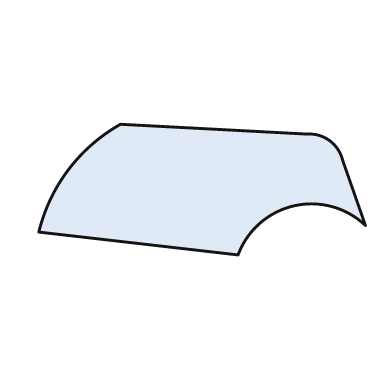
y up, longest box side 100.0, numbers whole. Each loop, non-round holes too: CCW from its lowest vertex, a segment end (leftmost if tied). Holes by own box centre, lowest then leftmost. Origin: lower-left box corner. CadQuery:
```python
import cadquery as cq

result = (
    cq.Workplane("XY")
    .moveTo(61.0, 0.0)
    .threePointArc((78.0, 15.0), (100.0, 9.0))
    .lineTo(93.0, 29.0)
    .threePointArc((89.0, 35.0), (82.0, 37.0))
    .lineTo(25.0, 40.0)
    .threePointArc((9.0, 26.0), (0.0, 7.0))
    .close()
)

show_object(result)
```